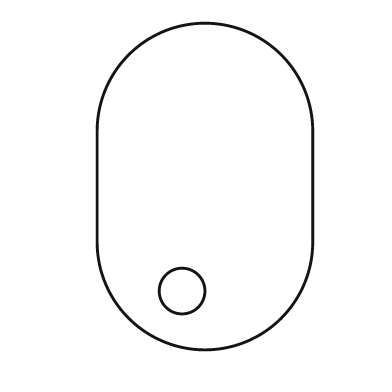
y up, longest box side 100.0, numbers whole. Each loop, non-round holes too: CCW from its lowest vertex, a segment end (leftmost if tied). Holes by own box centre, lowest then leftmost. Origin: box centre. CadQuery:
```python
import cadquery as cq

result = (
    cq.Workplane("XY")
    .moveTo(-33.0, -17.0)
    .threePointArc((0.0, -50.0), (33.0, -17.0))
    .lineTo(33.0, 17.0)
    .threePointArc((0.0, 50.0), (-33.0, 17.0))
    .close()
    .moveTo(-7.0, -32.0)
    .circle(7.0)
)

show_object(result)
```